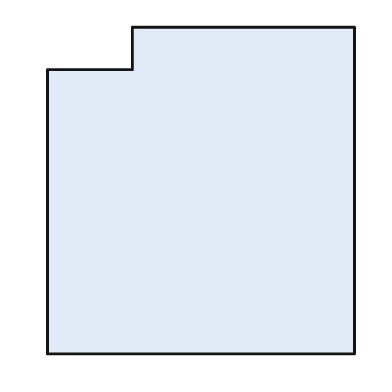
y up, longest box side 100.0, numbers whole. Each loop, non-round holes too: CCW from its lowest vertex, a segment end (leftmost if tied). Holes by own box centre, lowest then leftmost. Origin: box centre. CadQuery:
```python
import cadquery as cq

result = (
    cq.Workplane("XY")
    .moveTo(-47.0, -50.0)
    .lineTo(47.0, -50.0)
    .lineTo(47.0, 50.0)
    .lineTo(-21.0, 50.0)
    .lineTo(-21.0, 37.0)
    .lineTo(-47.0, 37.0)
    .close()
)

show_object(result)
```